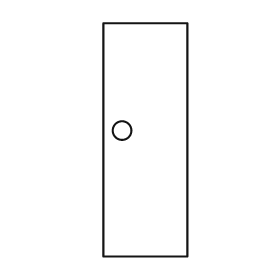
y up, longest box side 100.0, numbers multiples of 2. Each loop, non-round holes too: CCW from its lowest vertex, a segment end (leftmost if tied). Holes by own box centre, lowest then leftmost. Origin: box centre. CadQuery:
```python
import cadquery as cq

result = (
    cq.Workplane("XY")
    .moveTo(-18.0, -50.0)
    .lineTo(18.0, -50.0)
    .lineTo(18.0, 50.0)
    .lineTo(-18.0, 50.0)
    .close()
    .moveTo(-10.0, 4.0)
    .circle(4.0)
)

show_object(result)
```